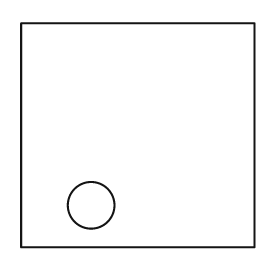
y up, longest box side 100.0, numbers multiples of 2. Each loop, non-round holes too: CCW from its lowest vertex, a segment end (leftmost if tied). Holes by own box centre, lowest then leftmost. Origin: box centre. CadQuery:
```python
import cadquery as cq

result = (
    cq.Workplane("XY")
    .moveTo(-50.0, -48.0)
    .lineTo(50.0, -48.0)
    .lineTo(50.0, 48.0)
    .lineTo(-50.0, 48.0)
    .close()
    .moveTo(-20.0, -30.0)
    .circle(10.0)
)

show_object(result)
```